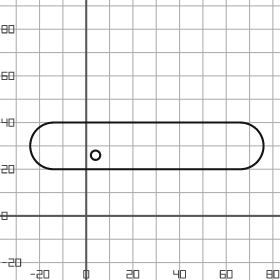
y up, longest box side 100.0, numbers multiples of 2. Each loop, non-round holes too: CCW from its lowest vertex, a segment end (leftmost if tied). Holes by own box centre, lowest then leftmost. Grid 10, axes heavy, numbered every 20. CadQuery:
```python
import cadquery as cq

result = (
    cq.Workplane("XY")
    .moveTo(-14.0, 20.0)
    .lineTo(66.0, 20.0)
    .threePointArc((76.0, 30.0), (66.0, 40.0))
    .lineTo(-14.0, 40.0)
    .threePointArc((-24.0, 30.0), (-14.0, 20.0))
    .close()
    .moveTo(4.0, 26.0)
    .circle(2.0)
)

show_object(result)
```